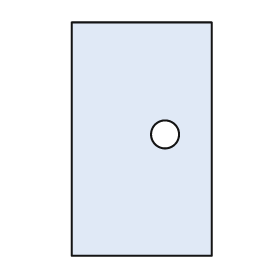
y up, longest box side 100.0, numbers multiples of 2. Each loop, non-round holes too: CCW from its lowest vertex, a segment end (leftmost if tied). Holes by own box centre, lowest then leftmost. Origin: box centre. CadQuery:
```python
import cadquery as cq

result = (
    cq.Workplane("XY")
    .moveTo(-30.0, -50.0)
    .lineTo(30.0, -50.0)
    .lineTo(30.0, 50.0)
    .lineTo(-30.0, 50.0)
    .close()
    .moveTo(10.0, 2.0)
    .circle(6.0)
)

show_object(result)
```